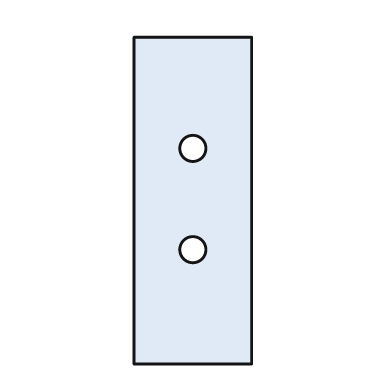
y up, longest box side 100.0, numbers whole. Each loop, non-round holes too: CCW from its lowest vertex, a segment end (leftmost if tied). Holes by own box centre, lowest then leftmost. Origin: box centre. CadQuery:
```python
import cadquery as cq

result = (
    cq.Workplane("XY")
    .moveTo(-18.0, -50.0)
    .lineTo(18.0, -50.0)
    .lineTo(18.0, 50.0)
    .lineTo(-18.0, 50.0)
    .close()
    .moveTo(0.0, -15.0)
    .circle(4.0)
    .moveTo(0.0, 16.0)
    .circle(4.0)
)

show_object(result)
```